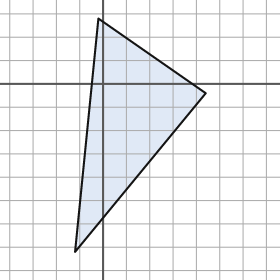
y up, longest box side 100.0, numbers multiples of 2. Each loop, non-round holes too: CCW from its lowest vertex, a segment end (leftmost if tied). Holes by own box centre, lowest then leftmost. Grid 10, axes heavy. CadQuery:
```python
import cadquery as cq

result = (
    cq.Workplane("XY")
    .moveTo(-12.0, -72.0)
    .lineTo(44.0, -4.0)
    .lineTo(-2.0, 28.0)
    .close()
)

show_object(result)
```